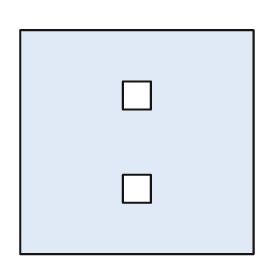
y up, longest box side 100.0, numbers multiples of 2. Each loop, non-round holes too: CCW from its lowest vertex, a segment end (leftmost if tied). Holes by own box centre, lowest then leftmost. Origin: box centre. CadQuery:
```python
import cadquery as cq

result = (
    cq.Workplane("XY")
    .moveTo(-50.0, -48.0)
    .lineTo(50.0, -48.0)
    .lineTo(50.0, 48.0)
    .lineTo(-50.0, 48.0)
    .close()
    .moveTo(-6.0, -26.0)
    .lineTo(6.0, -26.0)
    .lineTo(6.0, -14.0)
    .lineTo(-6.0, -14.0)
    .close()
    .moveTo(-6.0, 14.0)
    .lineTo(6.0, 14.0)
    .lineTo(6.0, 26.0)
    .lineTo(-6.0, 26.0)
    .close()
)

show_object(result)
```